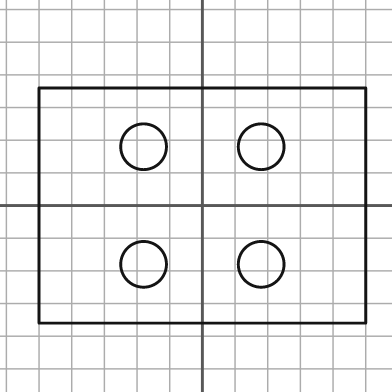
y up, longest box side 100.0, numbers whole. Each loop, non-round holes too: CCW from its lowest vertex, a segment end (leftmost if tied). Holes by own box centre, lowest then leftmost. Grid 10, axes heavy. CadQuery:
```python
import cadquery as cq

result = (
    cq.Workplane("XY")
    .moveTo(-50.0, -36.0)
    .lineTo(50.0, -36.0)
    .lineTo(50.0, 36.0)
    .lineTo(-50.0, 36.0)
    .close()
    .moveTo(-18.0, -18.0)
    .circle(7.0)
    .moveTo(18.0, -18.0)
    .circle(7.0)
    .moveTo(-18.0, 18.0)
    .circle(7.0)
    .moveTo(18.0, 18.0)
    .circle(7.0)
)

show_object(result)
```